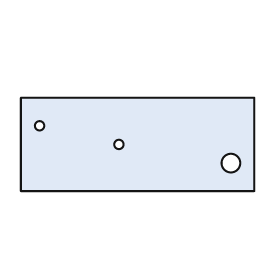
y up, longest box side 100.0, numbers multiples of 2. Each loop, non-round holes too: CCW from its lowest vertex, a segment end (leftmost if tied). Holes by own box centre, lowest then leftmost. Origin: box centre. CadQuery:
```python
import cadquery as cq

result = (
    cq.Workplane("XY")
    .moveTo(-50.0, -20.0)
    .lineTo(50.0, -20.0)
    .lineTo(50.0, 20.0)
    .lineTo(-50.0, 20.0)
    .close()
    .moveTo(40.0, -8.0)
    .circle(4.0)
    .moveTo(-8.0, 0.0)
    .circle(2.0)
    .moveTo(-42.0, 8.0)
    .circle(2.0)
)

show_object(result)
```